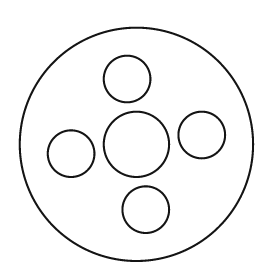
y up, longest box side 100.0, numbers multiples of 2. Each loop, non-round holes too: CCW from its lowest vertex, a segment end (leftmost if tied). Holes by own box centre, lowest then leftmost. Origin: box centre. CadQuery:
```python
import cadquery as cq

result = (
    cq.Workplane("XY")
    .moveTo(0.0, 0.0)
    .circle(50.0)
    .moveTo(4.0, -28.0)
    .circle(10.0)
    .moveTo(-28.0, -4.0)
    .circle(10.0)
    .moveTo(0.0, 0.0)
    .circle(14.0)
    .moveTo(28.0, 4.0)
    .circle(10.0)
    .moveTo(-4.0, 28.0)
    .circle(10.0)
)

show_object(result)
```